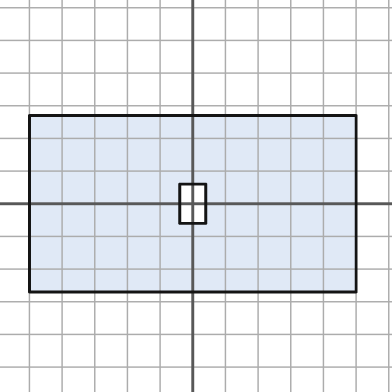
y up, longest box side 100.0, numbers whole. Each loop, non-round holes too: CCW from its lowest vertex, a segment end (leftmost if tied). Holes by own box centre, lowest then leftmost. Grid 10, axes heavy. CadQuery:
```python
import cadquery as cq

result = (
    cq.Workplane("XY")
    .moveTo(-50.0, -27.0)
    .lineTo(50.0, -27.0)
    .lineTo(50.0, 27.0)
    .lineTo(-50.0, 27.0)
    .close()
    .moveTo(-4.0, -6.0)
    .lineTo(4.0, -6.0)
    .lineTo(4.0, 6.0)
    .lineTo(-4.0, 6.0)
    .close()
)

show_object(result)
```